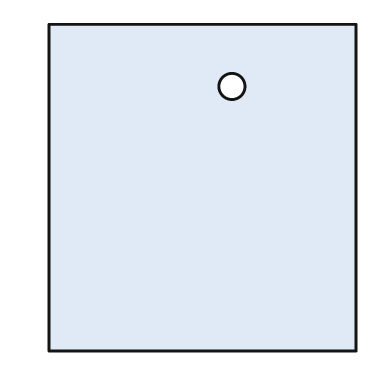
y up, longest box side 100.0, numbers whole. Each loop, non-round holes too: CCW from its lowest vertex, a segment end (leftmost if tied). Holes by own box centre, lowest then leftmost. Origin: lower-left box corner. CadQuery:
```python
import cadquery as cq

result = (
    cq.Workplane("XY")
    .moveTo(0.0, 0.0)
    .lineTo(94.0, 0.0)
    .lineTo(94.0, 100.0)
    .lineTo(0.0, 100.0)
    .close()
    .moveTo(56.0, 81.0)
    .circle(4.0)
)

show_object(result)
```